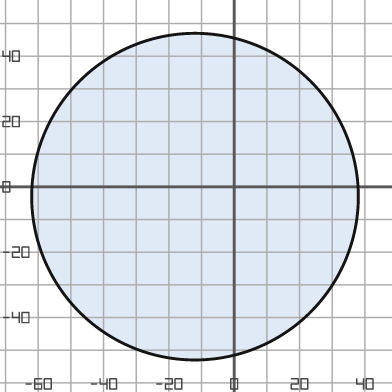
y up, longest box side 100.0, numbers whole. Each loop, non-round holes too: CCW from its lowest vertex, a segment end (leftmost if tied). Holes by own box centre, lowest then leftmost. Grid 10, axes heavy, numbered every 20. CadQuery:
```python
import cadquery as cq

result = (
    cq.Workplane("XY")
    .moveTo(-12.0, -3.0)
    .circle(50.0)
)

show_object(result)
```